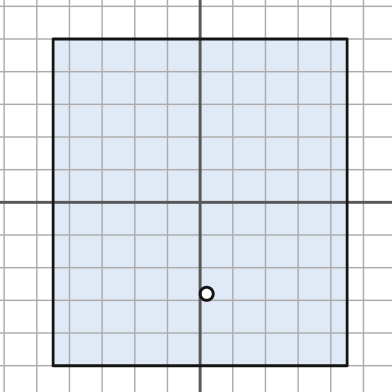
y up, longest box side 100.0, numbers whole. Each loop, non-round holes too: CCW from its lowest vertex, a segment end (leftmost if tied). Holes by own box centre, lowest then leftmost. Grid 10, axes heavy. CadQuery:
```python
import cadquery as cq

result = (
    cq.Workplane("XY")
    .moveTo(-45.0, -50.0)
    .lineTo(45.0, -50.0)
    .lineTo(45.0, 50.0)
    .lineTo(-45.0, 50.0)
    .close()
    .moveTo(2.0, -28.0)
    .circle(2.0)
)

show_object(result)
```